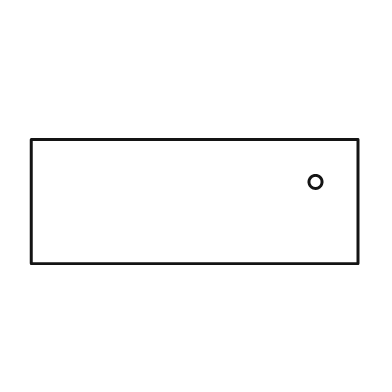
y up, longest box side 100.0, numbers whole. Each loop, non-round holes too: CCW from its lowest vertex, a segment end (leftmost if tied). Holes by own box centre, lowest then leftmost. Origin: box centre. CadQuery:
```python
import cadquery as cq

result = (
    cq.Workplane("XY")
    .moveTo(-50.0, -19.0)
    .lineTo(50.0, -19.0)
    .lineTo(50.0, 19.0)
    .lineTo(-50.0, 19.0)
    .close()
    .moveTo(37.0, 6.0)
    .circle(2.0)
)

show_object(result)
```